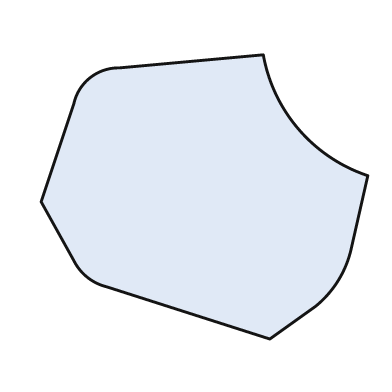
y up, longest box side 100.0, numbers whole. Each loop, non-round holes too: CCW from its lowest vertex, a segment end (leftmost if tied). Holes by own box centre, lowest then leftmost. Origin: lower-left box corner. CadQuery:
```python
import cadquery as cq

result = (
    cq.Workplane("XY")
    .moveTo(70.0, 0.0)
    .lineTo(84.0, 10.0)
    .threePointArc((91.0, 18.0), (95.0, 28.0))
    .lineTo(100.0, 50.0)
    .threePointArc((79.0, 64.0), (68.0, 87.0))
    .lineTo(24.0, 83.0)
    .threePointArc((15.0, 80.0), (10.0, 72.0))
    .lineTo(0.0, 42.0)
    .lineTo(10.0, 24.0)
    .threePointArc((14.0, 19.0), (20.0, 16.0))
    .close()
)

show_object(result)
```